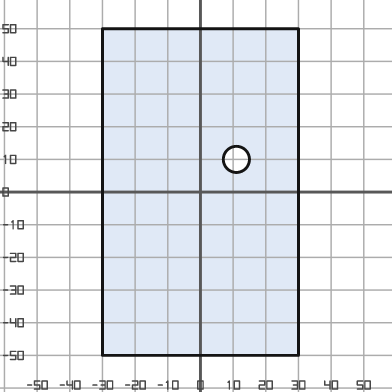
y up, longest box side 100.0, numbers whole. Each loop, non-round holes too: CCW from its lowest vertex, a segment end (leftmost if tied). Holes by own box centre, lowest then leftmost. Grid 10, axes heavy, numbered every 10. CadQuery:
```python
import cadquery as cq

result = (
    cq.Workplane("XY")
    .moveTo(-30.0, -50.0)
    .lineTo(30.0, -50.0)
    .lineTo(30.0, 50.0)
    .lineTo(-30.0, 50.0)
    .close()
    .moveTo(11.0, 10.0)
    .circle(4.0)
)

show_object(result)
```